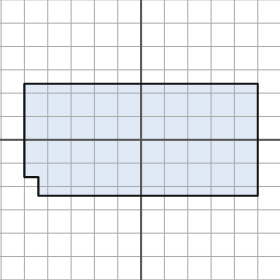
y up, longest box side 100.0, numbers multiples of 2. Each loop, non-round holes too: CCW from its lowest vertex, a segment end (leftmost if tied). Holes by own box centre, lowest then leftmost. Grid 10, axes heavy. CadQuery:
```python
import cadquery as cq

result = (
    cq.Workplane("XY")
    .moveTo(-44.0, -24.0)
    .lineTo(50.0, -24.0)
    .lineTo(50.0, 24.0)
    .lineTo(-50.0, 24.0)
    .lineTo(-50.0, -16.0)
    .lineTo(-44.0, -16.0)
    .close()
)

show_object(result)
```